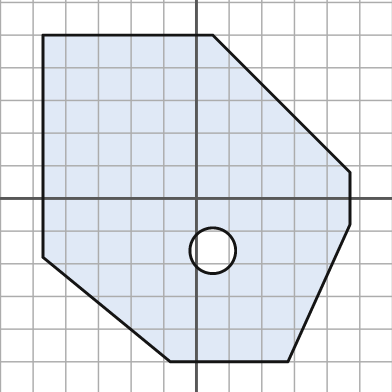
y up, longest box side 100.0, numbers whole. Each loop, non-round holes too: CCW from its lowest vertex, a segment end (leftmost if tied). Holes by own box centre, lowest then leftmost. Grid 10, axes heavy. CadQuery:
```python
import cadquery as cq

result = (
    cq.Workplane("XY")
    .moveTo(-8.0, -50.0)
    .lineTo(28.0, -50.0)
    .lineTo(47.0, -8.0)
    .lineTo(47.0, 8.0)
    .lineTo(5.0, 50.0)
    .lineTo(-47.0, 50.0)
    .lineTo(-47.0, -18.0)
    .close()
    .moveTo(5.0, -16.0)
    .circle(7.0)
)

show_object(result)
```